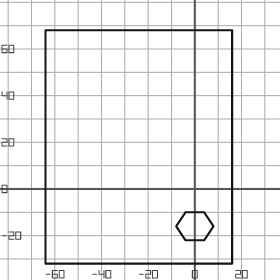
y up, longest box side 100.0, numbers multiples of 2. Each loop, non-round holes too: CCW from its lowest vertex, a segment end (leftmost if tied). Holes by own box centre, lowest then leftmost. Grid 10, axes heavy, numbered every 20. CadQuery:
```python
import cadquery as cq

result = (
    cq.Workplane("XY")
    .moveTo(-64.0, -32.0)
    .lineTo(16.0, -32.0)
    .lineTo(16.0, 68.0)
    .lineTo(-64.0, 68.0)
    .close()
    .moveTo(-4.0, -22.0)
    .lineTo(4.0, -22.0)
    .lineTo(8.0, -16.0)
    .lineTo(4.0, -10.0)
    .lineTo(-4.0, -10.0)
    .lineTo(-8.0, -16.0)
    .close()
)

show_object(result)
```